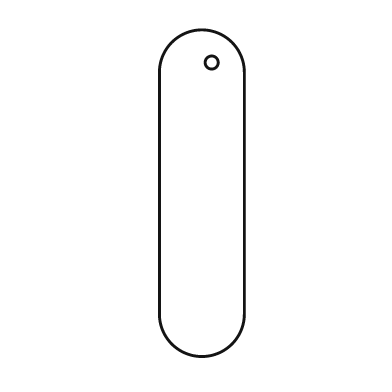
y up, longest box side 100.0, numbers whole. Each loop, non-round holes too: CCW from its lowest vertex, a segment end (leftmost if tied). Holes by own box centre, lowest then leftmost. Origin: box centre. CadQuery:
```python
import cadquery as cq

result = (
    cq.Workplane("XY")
    .moveTo(-13.0, -37.0)
    .threePointArc((0.0, -50.0), (13.0, -37.0))
    .lineTo(13.0, 37.0)
    .threePointArc((0.0, 50.0), (-13.0, 37.0))
    .close()
    .moveTo(3.0, 40.0)
    .circle(2.0)
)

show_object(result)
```